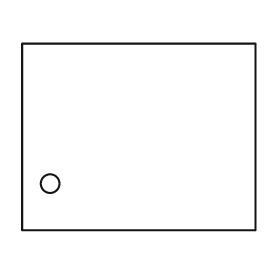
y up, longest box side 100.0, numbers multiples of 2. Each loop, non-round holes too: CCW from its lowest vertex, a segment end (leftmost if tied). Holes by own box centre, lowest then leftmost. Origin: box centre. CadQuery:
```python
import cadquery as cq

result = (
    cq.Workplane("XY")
    .moveTo(-50.0, -40.0)
    .lineTo(50.0, -40.0)
    .lineTo(50.0, 40.0)
    .lineTo(-50.0, 40.0)
    .close()
    .moveTo(-38.0, -20.0)
    .circle(4.0)
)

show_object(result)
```